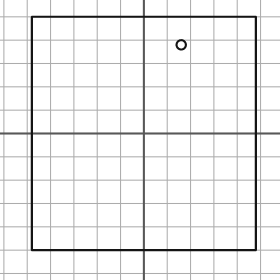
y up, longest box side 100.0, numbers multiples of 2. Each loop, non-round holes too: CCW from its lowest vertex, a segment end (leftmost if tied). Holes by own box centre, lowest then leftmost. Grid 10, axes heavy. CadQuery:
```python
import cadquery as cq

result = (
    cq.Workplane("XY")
    .moveTo(-48.0, -50.0)
    .lineTo(48.0, -50.0)
    .lineTo(48.0, 50.0)
    .lineTo(-48.0, 50.0)
    .close()
    .moveTo(16.0, 38.0)
    .circle(2.0)
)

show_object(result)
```